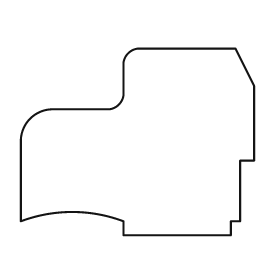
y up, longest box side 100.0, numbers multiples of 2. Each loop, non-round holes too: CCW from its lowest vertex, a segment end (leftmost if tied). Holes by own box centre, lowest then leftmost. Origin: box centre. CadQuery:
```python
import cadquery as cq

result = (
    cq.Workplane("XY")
    .moveTo(-6.0, -40.0)
    .lineTo(40.0, -40.0)
    .lineTo(40.0, -34.0)
    .lineTo(44.0, -34.0)
    .lineTo(44.0, -8.0)
    .lineTo(50.0, -8.0)
    .lineTo(50.0, 24.0)
    .lineTo(42.0, 40.0)
    .lineTo(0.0, 40.0)
    .threePointArc((-4.0, 38.0), (-6.0, 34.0))
    .lineTo(-6.0, 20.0)
    .threePointArc((-8.0, 16.0), (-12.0, 14.0))
    .lineTo(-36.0, 14.0)
    .threePointArc((-46.0, 10.0), (-50.0, 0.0))
    .lineTo(-50.0, -34.0)
    .threePointArc((-28.0, -30.0), (-6.0, -34.0))
    .close()
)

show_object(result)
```